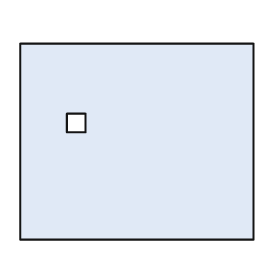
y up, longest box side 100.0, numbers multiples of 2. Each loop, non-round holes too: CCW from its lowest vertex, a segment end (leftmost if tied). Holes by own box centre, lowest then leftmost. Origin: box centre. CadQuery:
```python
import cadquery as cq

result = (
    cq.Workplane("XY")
    .moveTo(-50.0, -42.0)
    .lineTo(50.0, -42.0)
    .lineTo(50.0, 42.0)
    .lineTo(-50.0, 42.0)
    .close()
    .moveTo(-30.0, 4.0)
    .lineTo(-22.0, 4.0)
    .lineTo(-22.0, 12.0)
    .lineTo(-30.0, 12.0)
    .close()
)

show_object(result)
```